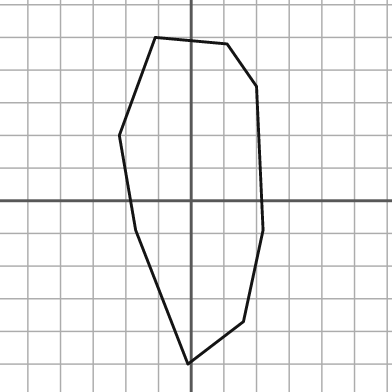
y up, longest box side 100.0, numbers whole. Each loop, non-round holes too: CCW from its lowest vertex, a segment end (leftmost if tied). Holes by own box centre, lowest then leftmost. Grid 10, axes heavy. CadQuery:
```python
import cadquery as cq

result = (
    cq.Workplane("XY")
    .moveTo(-1.0, -50.0)
    .lineTo(16.0, -37.0)
    .lineTo(22.0, -9.0)
    .lineTo(20.0, 35.0)
    .lineTo(11.0, 48.0)
    .lineTo(-11.0, 50.0)
    .lineTo(-22.0, 20.0)
    .lineTo(-17.0, -9.0)
    .close()
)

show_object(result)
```